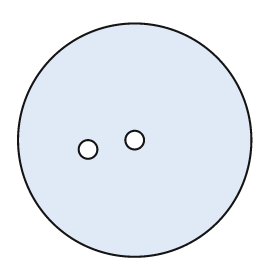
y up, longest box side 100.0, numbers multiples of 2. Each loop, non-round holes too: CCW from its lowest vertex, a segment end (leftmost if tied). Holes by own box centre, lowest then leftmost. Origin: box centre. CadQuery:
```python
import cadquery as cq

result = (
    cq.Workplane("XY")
    .moveTo(0.0, 0.0)
    .circle(50.0)
    .moveTo(-20.0, -4.0)
    .circle(4.0)
    .moveTo(0.0, 0.0)
    .circle(4.0)
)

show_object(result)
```